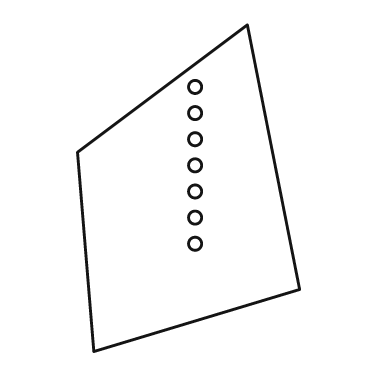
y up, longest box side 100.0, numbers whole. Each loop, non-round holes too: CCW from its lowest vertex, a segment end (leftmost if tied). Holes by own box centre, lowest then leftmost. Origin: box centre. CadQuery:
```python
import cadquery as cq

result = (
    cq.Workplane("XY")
    .moveTo(-29.0, -50.0)
    .lineTo(34.0, -31.0)
    .lineTo(18.0, 50.0)
    .lineTo(-34.0, 11.0)
    .close()
    .moveTo(2.0, -17.0)
    .circle(2.0)
    .moveTo(2.0, -9.0)
    .circle(2.0)
    .moveTo(2.0, -1.0)
    .circle(2.0)
    .moveTo(2.0, 7.0)
    .circle(2.0)
    .moveTo(2.0, 15.0)
    .circle(2.0)
    .moveTo(2.0, 23.0)
    .circle(2.0)
    .moveTo(2.0, 31.0)
    .circle(2.0)
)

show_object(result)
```